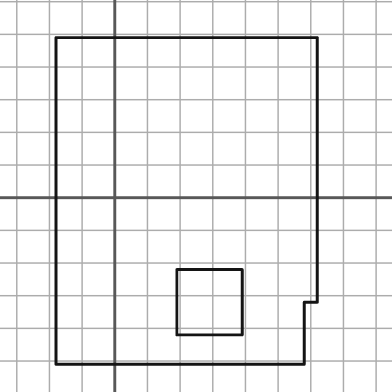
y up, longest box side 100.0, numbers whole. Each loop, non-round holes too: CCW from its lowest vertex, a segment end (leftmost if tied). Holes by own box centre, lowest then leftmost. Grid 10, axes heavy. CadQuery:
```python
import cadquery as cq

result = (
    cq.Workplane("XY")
    .moveTo(-18.0, -51.0)
    .lineTo(58.0, -51.0)
    .lineTo(58.0, -32.0)
    .lineTo(62.0, -32.0)
    .lineTo(62.0, 49.0)
    .lineTo(-18.0, 49.0)
    .close()
    .moveTo(19.0, -42.0)
    .lineTo(39.0, -42.0)
    .lineTo(39.0, -22.0)
    .lineTo(19.0, -22.0)
    .close()
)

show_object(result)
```